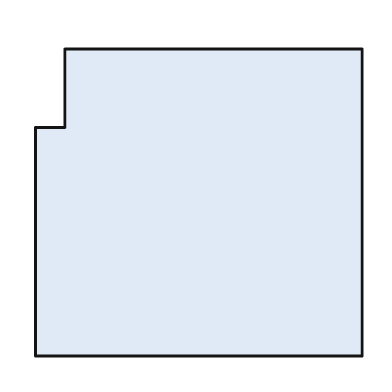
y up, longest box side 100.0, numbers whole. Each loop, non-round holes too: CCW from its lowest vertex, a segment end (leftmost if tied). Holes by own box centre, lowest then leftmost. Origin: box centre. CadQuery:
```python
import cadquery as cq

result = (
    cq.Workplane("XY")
    .moveTo(-50.0, -47.0)
    .lineTo(50.0, -47.0)
    .lineTo(50.0, 47.0)
    .lineTo(-41.0, 47.0)
    .lineTo(-41.0, 23.0)
    .lineTo(-50.0, 23.0)
    .close()
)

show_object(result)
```